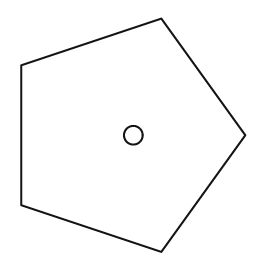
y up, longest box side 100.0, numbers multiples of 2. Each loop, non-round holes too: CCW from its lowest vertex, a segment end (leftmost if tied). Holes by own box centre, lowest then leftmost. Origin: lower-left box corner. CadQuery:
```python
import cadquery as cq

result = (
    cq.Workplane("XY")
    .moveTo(60.0, 0.0)
    .lineTo(96.0, 50.0)
    .lineTo(60.0, 100.0)
    .lineTo(0.0, 80.0)
    .lineTo(0.0, 20.0)
    .close()
    .moveTo(48.0, 50.0)
    .circle(4.0)
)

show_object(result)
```